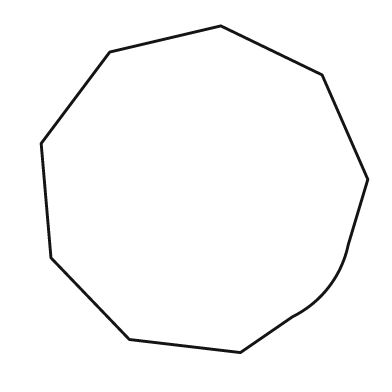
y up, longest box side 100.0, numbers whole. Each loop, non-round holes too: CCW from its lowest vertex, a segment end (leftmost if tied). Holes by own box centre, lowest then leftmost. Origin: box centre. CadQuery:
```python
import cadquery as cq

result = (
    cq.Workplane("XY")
    .moveTo(11.0, -50.0)
    .lineTo(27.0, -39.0)
    .threePointArc((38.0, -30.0), (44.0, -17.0))
    .lineTo(50.0, 3.0)
    .lineTo(36.0, 35.0)
    .lineTo(5.0, 50.0)
    .lineTo(-29.0, 42.0)
    .lineTo(-50.0, 14.0)
    .lineTo(-47.0, -21.0)
    .lineTo(-23.0, -46.0)
    .close()
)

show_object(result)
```